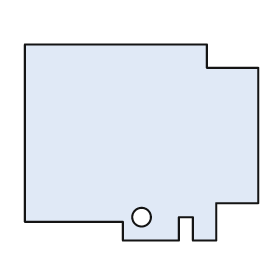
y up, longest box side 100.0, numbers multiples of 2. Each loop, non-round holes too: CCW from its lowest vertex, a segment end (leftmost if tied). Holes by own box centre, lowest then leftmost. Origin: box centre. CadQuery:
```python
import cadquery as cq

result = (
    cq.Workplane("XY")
    .moveTo(-8.0, -42.0)
    .lineTo(16.0, -42.0)
    .lineTo(16.0, -32.0)
    .lineTo(22.0, -32.0)
    .lineTo(22.0, -42.0)
    .lineTo(32.0, -42.0)
    .lineTo(32.0, -26.0)
    .lineTo(50.0, -26.0)
    .lineTo(50.0, 32.0)
    .lineTo(28.0, 32.0)
    .lineTo(28.0, 42.0)
    .lineTo(-50.0, 42.0)
    .lineTo(-50.0, -34.0)
    .lineTo(-8.0, -34.0)
    .close()
    .moveTo(0.0, -32.0)
    .circle(4.0)
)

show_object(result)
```